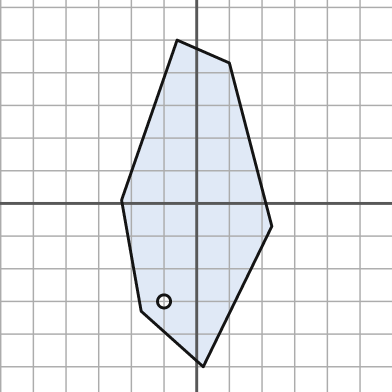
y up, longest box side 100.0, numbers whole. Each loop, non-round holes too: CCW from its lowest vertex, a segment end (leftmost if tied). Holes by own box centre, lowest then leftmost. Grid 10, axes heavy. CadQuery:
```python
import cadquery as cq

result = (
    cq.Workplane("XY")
    .moveTo(2.0, -50.0)
    .lineTo(23.0, -7.0)
    .lineTo(10.0, 43.0)
    .lineTo(-6.0, 50.0)
    .lineTo(-23.0, 1.0)
    .lineTo(-17.0, -33.0)
    .close()
    .moveTo(-10.0, -30.0)
    .circle(2.0)
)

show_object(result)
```